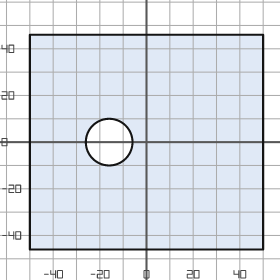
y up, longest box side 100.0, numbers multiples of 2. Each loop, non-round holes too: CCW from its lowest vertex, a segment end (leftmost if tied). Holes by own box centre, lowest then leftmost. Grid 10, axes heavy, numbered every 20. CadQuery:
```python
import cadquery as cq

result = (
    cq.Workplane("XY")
    .moveTo(-50.0, -46.0)
    .lineTo(50.0, -46.0)
    .lineTo(50.0, 46.0)
    .lineTo(-50.0, 46.0)
    .close()
    .moveTo(-16.0, 0.0)
    .circle(10.0)
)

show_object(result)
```